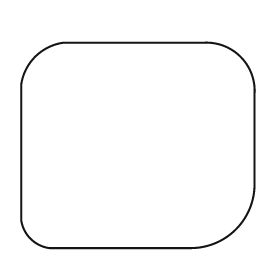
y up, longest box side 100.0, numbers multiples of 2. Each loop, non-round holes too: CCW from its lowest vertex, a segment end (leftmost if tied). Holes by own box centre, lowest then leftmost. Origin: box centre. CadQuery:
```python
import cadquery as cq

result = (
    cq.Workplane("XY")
    .moveTo(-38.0, -44.0)
    .lineTo(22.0, -44.0)
    .threePointArc((42.0, -36.0), (50.0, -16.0))
    .lineTo(50.0, 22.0)
    .threePointArc((44.0, 38.0), (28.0, 44.0))
    .lineTo(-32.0, 44.0)
    .threePointArc((-44.0, 38.0), (-50.0, 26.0))
    .lineTo(-50.0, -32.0)
    .threePointArc((-46.0, -40.0), (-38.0, -44.0))
    .close()
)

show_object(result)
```